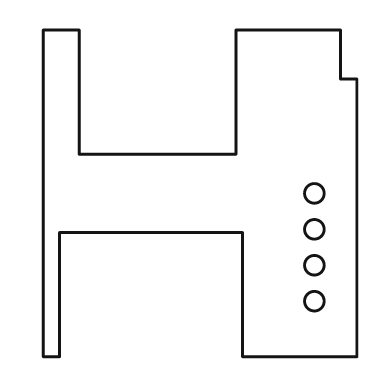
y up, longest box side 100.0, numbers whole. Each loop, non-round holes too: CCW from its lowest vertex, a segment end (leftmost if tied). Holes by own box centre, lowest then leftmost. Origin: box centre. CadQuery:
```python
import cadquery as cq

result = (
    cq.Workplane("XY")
    .moveTo(-48.0, -50.0)
    .lineTo(-43.0, -50.0)
    .lineTo(-43.0, -12.0)
    .lineTo(13.0, -12.0)
    .lineTo(13.0, -50.0)
    .lineTo(48.0, -50.0)
    .lineTo(48.0, 35.0)
    .lineTo(43.0, 35.0)
    .lineTo(43.0, 50.0)
    .lineTo(11.0, 50.0)
    .lineTo(11.0, 12.0)
    .lineTo(-37.0, 12.0)
    .lineTo(-37.0, 50.0)
    .lineTo(-48.0, 50.0)
    .close()
    .moveTo(35.0, -33.0)
    .circle(3.0)
    .moveTo(35.0, -22.0)
    .circle(3.0)
    .moveTo(35.0, -11.0)
    .circle(3.0)
    .moveTo(35.0, 0.0)
    .circle(3.0)
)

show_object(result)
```